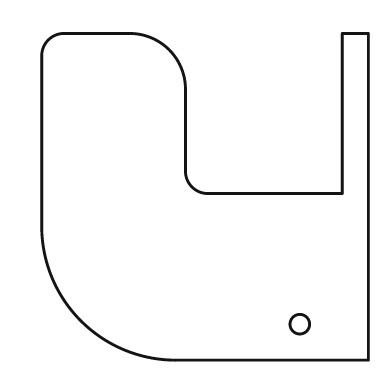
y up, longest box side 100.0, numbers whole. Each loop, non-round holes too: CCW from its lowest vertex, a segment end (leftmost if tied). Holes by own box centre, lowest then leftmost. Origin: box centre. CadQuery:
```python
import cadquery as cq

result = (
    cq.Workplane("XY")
    .moveTo(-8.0, -50.0)
    .lineTo(50.0, -50.0)
    .lineTo(50.0, 50.0)
    .lineTo(42.0, 50.0)
    .lineTo(42.0, 1.0)
    .lineTo(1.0, 1.0)
    .threePointArc((-4.0, 3.0), (-6.0, 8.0))
    .lineTo(-6.0, 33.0)
    .threePointArc((-11.0, 45.0), (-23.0, 50.0))
    .lineTo(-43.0, 50.0)
    .threePointArc((-48.0, 48.0), (-50.0, 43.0))
    .lineTo(-50.0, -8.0)
    .threePointArc((-38.0, -38.0), (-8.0, -50.0))
    .close()
    .moveTo(29.0, -39.0)
    .circle(3.0)
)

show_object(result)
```